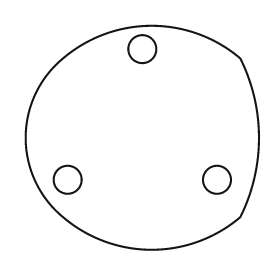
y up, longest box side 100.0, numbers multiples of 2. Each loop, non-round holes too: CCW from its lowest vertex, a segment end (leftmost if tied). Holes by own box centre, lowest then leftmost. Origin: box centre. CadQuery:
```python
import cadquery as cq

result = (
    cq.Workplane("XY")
    .moveTo(-34.0, -34.0)
    .threePointArc((4.0, -48.0), (42.0, -34.0))
    .threePointArc((50.0, 0.0), (42.0, 34.0))
    .threePointArc((4.0, 48.0), (-34.0, 34.0))
    .threePointArc((-50.0, 0.0), (-34.0, -34.0))
    .close()
    .moveTo(-32.0, -18.0)
    .circle(6.0)
    .moveTo(32.0, -18.0)
    .circle(6.0)
    .moveTo(0.0, 38.0)
    .circle(6.0)
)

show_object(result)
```